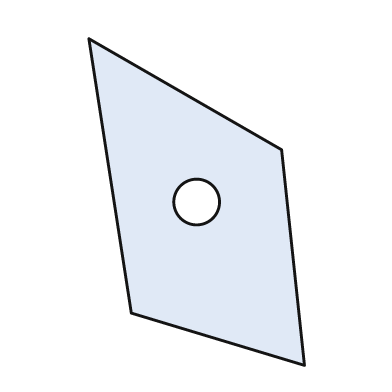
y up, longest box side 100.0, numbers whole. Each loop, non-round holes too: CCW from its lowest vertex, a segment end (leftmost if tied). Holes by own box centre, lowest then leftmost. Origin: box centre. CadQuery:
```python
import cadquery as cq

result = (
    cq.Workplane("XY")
    .moveTo(33.0, -50.0)
    .lineTo(26.0, 16.0)
    .lineTo(-33.0, 50.0)
    .lineTo(-20.0, -34.0)
    .close()
    .moveTo(0.0, 0.0)
    .circle(7.0)
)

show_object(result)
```